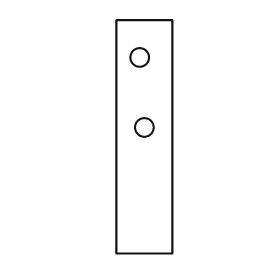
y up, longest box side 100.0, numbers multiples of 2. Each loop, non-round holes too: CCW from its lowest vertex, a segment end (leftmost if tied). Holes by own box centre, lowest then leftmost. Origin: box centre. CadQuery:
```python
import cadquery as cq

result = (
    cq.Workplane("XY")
    .moveTo(-12.0, -50.0)
    .lineTo(12.0, -50.0)
    .lineTo(12.0, 50.0)
    .lineTo(-12.0, 50.0)
    .close()
    .moveTo(0.0, 4.0)
    .circle(4.0)
    .moveTo(-2.0, 34.0)
    .circle(4.0)
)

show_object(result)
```